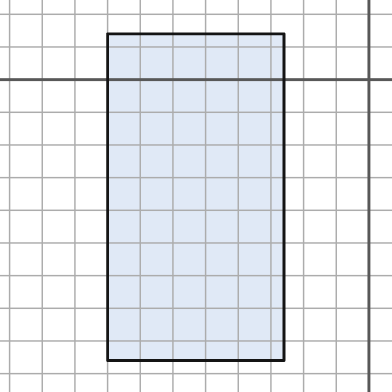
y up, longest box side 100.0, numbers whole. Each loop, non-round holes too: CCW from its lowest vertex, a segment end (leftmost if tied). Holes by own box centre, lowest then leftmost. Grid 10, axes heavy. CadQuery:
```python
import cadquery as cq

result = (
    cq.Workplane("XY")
    .moveTo(-80.0, -86.0)
    .lineTo(-26.0, -86.0)
    .lineTo(-26.0, 14.0)
    .lineTo(-80.0, 14.0)
    .close()
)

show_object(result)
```